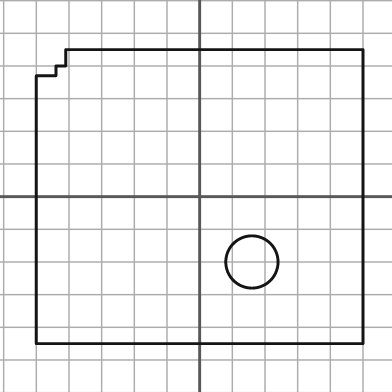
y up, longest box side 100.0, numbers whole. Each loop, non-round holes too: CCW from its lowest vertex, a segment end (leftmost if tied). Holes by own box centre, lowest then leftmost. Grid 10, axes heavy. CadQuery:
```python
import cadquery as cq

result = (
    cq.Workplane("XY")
    .moveTo(-50.0, -45.0)
    .lineTo(50.0, -45.0)
    .lineTo(50.0, 45.0)
    .lineTo(-41.0, 45.0)
    .lineTo(-41.0, 40.0)
    .lineTo(-44.0, 40.0)
    .lineTo(-44.0, 37.0)
    .lineTo(-50.0, 37.0)
    .close()
    .moveTo(16.0, -20.0)
    .circle(8.0)
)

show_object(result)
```